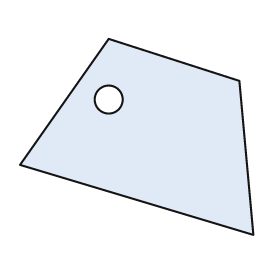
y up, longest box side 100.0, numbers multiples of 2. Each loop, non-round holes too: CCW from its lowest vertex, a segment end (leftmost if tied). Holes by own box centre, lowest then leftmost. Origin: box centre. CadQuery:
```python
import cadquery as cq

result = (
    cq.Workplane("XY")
    .moveTo(50.0, -42.0)
    .lineTo(44.0, 24.0)
    .lineTo(-12.0, 42.0)
    .lineTo(-50.0, -12.0)
    .close()
    .moveTo(-12.0, 16.0)
    .circle(6.0)
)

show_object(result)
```